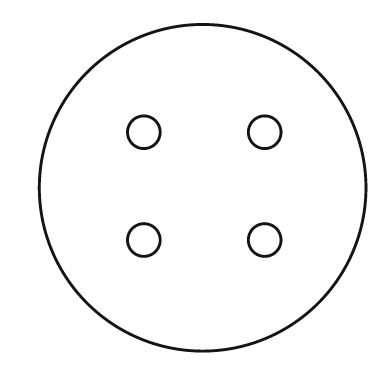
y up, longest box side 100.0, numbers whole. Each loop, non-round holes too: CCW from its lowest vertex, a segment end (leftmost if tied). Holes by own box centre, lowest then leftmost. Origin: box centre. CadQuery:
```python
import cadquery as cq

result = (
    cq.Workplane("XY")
    .moveTo(0.0, 0.0)
    .circle(50.0)
    .moveTo(-18.0, -16.0)
    .circle(5.0)
    .moveTo(19.0, -16.0)
    .circle(5.0)
    .moveTo(-18.0, 17.0)
    .circle(5.0)
    .moveTo(19.0, 17.0)
    .circle(5.0)
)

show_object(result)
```